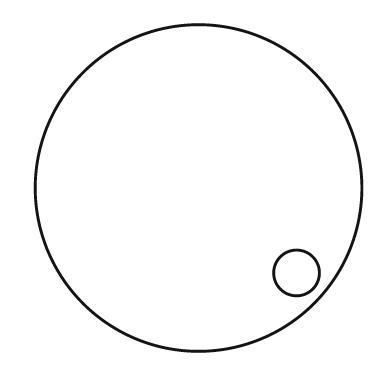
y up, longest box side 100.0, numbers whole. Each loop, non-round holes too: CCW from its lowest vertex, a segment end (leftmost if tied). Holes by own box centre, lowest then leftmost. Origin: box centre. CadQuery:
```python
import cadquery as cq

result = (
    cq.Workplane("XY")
    .moveTo(0.0, 0.0)
    .circle(50.0)
    .moveTo(30.0, -26.0)
    .circle(7.0)
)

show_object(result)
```